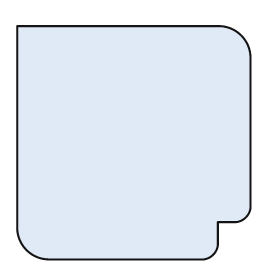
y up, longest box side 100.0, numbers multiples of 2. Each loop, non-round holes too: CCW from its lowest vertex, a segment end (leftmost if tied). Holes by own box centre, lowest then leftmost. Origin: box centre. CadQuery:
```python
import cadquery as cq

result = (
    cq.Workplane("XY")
    .moveTo(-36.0, -50.0)
    .lineTo(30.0, -50.0)
    .threePointArc((34.0, -48.0), (36.0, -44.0))
    .lineTo(36.0, -34.0)
    .lineTo(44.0, -34.0)
    .threePointArc((48.0, -32.0), (50.0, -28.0))
    .lineTo(50.0, 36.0)
    .threePointArc((46.0, 46.0), (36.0, 50.0))
    .lineTo(-50.0, 50.0)
    .lineTo(-50.0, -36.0)
    .threePointArc((-46.0, -46.0), (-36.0, -50.0))
    .close()
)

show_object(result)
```